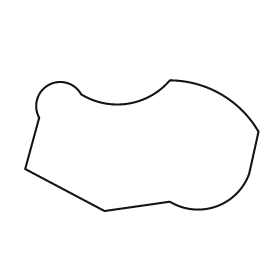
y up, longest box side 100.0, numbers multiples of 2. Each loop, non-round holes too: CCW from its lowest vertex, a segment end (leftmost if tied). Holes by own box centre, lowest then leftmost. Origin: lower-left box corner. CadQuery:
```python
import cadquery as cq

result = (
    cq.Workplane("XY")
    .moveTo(34.0, 0.0)
    .lineTo(62.0, 4.0)
    .threePointArc((82.0, 2.0), (96.0, 16.0))
    .lineTo(100.0, 34.0)
    .threePointArc((84.0, 50.0), (62.0, 56.0))
    .threePointArc((44.0, 46.0), (24.0, 50.0))
    .threePointArc((10.0, 54.0), (6.0, 40.0))
    .lineTo(0.0, 18.0)
    .close()
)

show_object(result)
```